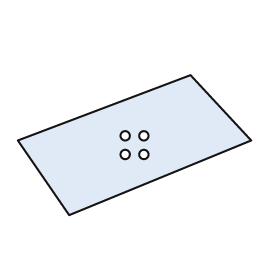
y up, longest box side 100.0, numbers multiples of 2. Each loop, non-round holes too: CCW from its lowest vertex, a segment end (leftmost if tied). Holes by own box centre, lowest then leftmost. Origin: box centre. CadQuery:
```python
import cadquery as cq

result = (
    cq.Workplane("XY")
    .moveTo(-28.0, -30.0)
    .lineTo(50.0, 2.0)
    .lineTo(24.0, 30.0)
    .lineTo(-50.0, 2.0)
    .close()
    .moveTo(-4.0, -4.0)
    .circle(2.0)
    .moveTo(4.0, -4.0)
    .circle(2.0)
    .moveTo(-4.0, 4.0)
    .circle(2.0)
    .moveTo(4.0, 4.0)
    .circle(2.0)
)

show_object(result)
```